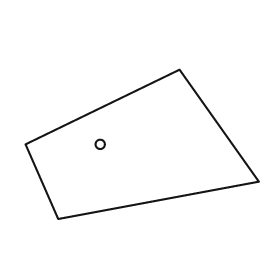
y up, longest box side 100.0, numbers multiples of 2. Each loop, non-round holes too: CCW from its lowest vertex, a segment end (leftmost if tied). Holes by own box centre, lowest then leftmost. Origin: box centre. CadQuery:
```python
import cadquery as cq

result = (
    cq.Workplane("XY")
    .moveTo(-36.0, -32.0)
    .lineTo(50.0, -16.0)
    .lineTo(16.0, 32.0)
    .lineTo(-50.0, 0.0)
    .close()
    .moveTo(-18.0, 0.0)
    .circle(2.0)
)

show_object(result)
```